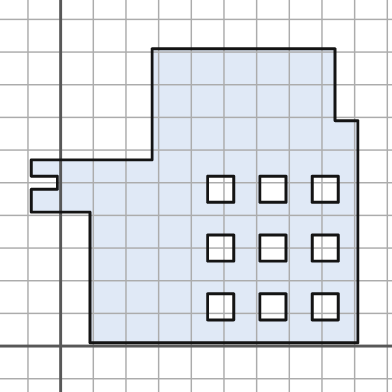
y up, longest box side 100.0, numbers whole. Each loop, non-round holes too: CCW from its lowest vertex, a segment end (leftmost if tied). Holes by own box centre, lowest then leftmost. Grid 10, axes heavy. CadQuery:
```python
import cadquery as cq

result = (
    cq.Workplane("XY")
    .moveTo(9.0, 1.0)
    .lineTo(91.0, 1.0)
    .lineTo(91.0, 69.0)
    .lineTo(84.0, 69.0)
    .lineTo(84.0, 91.0)
    .lineTo(28.0, 91.0)
    .lineTo(28.0, 57.0)
    .lineTo(-9.0, 57.0)
    .lineTo(-9.0, 52.0)
    .lineTo(-1.0, 52.0)
    .lineTo(-1.0, 48.0)
    .lineTo(-9.0, 48.0)
    .lineTo(-9.0, 41.0)
    .lineTo(9.0, 41.0)
    .close()
    .moveTo(45.0, 8.0)
    .lineTo(53.0, 8.0)
    .lineTo(53.0, 16.0)
    .lineTo(45.0, 16.0)
    .close()
    .moveTo(61.0, 8.0)
    .lineTo(69.0, 8.0)
    .lineTo(69.0, 16.0)
    .lineTo(61.0, 16.0)
    .close()
    .moveTo(77.0, 8.0)
    .lineTo(85.0, 8.0)
    .lineTo(85.0, 16.0)
    .lineTo(77.0, 16.0)
    .close()
    .moveTo(45.0, 26.0)
    .lineTo(53.0, 26.0)
    .lineTo(53.0, 34.0)
    .lineTo(45.0, 34.0)
    .close()
    .moveTo(61.0, 26.0)
    .lineTo(69.0, 26.0)
    .lineTo(69.0, 34.0)
    .lineTo(61.0, 34.0)
    .close()
    .moveTo(77.0, 26.0)
    .lineTo(85.0, 26.0)
    .lineTo(85.0, 34.0)
    .lineTo(77.0, 34.0)
    .close()
    .moveTo(45.0, 44.0)
    .lineTo(53.0, 44.0)
    .lineTo(53.0, 52.0)
    .lineTo(45.0, 52.0)
    .close()
    .moveTo(61.0, 44.0)
    .lineTo(69.0, 44.0)
    .lineTo(69.0, 52.0)
    .lineTo(61.0, 52.0)
    .close()
    .moveTo(77.0, 44.0)
    .lineTo(85.0, 44.0)
    .lineTo(85.0, 52.0)
    .lineTo(77.0, 52.0)
    .close()
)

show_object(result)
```